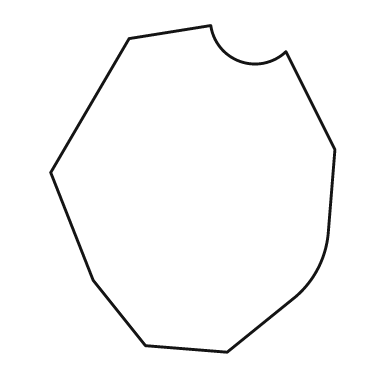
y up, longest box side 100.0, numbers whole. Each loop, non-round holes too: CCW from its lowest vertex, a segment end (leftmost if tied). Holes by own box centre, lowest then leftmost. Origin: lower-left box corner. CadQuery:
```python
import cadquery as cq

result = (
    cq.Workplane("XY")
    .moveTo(54.0, 0.0)
    .lineTo(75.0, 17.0)
    .threePointArc((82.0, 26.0), (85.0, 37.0))
    .lineTo(87.0, 62.0)
    .lineTo(72.0, 92.0)
    .threePointArc((58.0, 89.0), (49.0, 100.0))
    .lineTo(24.0, 96.0)
    .lineTo(0.0, 55.0)
    .lineTo(13.0, 22.0)
    .lineTo(29.0, 2.0)
    .close()
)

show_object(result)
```